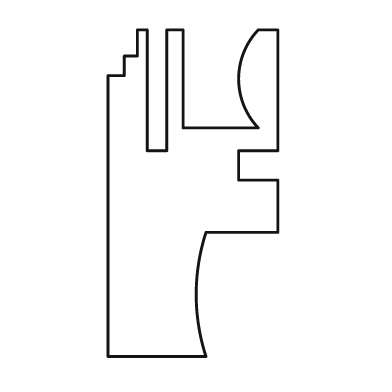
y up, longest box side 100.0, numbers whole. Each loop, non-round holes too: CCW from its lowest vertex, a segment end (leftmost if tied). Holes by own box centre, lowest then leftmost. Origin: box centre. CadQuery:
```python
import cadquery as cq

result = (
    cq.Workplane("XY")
    .moveTo(-26.0, -50.0)
    .lineTo(4.0, -50.0)
    .threePointArc((1.0, -31.0), (4.0, -12.0))
    .lineTo(26.0, -12.0)
    .lineTo(26.0, 4.0)
    .lineTo(14.0, 4.0)
    .lineTo(14.0, 13.0)
    .lineTo(26.0, 13.0)
    .lineTo(26.0, 50.0)
    .lineTo(20.0, 50.0)
    .threePointArc((14.0, 35.0), (20.0, 20.0))
    .lineTo(-3.0, 20.0)
    .lineTo(-3.0, 50.0)
    .lineTo(-8.0, 50.0)
    .lineTo(-8.0, 13.0)
    .lineTo(-14.0, 13.0)
    .lineTo(-14.0, 50.0)
    .lineTo(-17.0, 50.0)
    .lineTo(-17.0, 42.0)
    .lineTo(-21.0, 42.0)
    .lineTo(-21.0, 36.0)
    .lineTo(-26.0, 36.0)
    .close()
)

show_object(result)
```